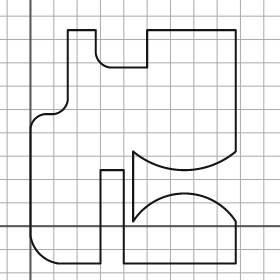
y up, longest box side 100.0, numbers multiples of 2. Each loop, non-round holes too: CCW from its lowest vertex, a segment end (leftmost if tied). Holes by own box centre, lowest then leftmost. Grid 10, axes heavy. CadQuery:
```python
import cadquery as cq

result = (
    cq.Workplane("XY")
    .moveTo(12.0, -16.0)
    .lineTo(30.0, -16.0)
    .lineTo(30.0, 24.0)
    .lineTo(40.0, 24.0)
    .lineTo(40.0, -16.0)
    .lineTo(88.0, -16.0)
    .lineTo(88.0, 2.0)
    .threePointArc((66.0, 14.0), (44.0, 2.0))
    .lineTo(44.0, 32.0)
    .threePointArc((66.0, 24.0), (88.0, 32.0))
    .lineTo(88.0, 84.0)
    .lineTo(50.0, 84.0)
    .lineTo(50.0, 68.0)
    .lineTo(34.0, 68.0)
    .threePointArc((30.0, 70.0), (28.0, 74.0))
    .lineTo(28.0, 84.0)
    .lineTo(16.0, 84.0)
    .lineTo(16.0, 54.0)
    .threePointArc((14.0, 50.0), (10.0, 48.0))
    .lineTo(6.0, 48.0)
    .threePointArc((2.0, 46.0), (0.0, 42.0))
    .lineTo(0.0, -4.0)
    .threePointArc((4.0, -12.0), (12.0, -16.0))
    .close()
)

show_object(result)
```